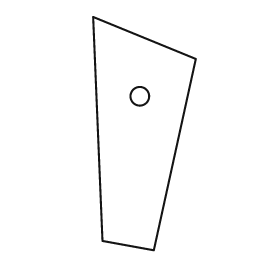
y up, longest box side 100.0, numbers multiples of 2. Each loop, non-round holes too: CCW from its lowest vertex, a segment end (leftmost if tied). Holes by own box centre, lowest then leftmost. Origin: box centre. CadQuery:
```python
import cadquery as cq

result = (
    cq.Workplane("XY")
    .moveTo(4.0, -50.0)
    .lineTo(22.0, 32.0)
    .lineTo(-22.0, 50.0)
    .lineTo(-18.0, -46.0)
    .close()
    .moveTo(-2.0, 16.0)
    .circle(4.0)
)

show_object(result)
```